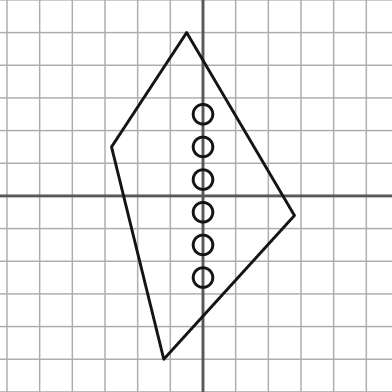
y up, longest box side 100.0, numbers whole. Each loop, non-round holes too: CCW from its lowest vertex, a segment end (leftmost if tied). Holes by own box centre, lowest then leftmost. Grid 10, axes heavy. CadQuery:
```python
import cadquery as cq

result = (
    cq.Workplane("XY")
    .moveTo(-12.0, -50.0)
    .lineTo(28.0, -6.0)
    .lineTo(-5.0, 50.0)
    .lineTo(-28.0, 15.0)
    .close()
    .moveTo(0.0, -25.0)
    .circle(3.0)
    .moveTo(0.0, -15.0)
    .circle(3.0)
    .moveTo(0.0, -5.0)
    .circle(3.0)
    .moveTo(0.0, 5.0)
    .circle(3.0)
    .moveTo(0.0, 15.0)
    .circle(3.0)
    .moveTo(0.0, 25.0)
    .circle(3.0)
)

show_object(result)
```